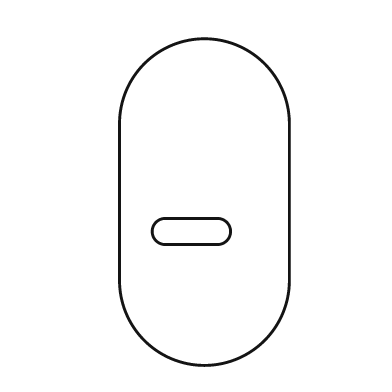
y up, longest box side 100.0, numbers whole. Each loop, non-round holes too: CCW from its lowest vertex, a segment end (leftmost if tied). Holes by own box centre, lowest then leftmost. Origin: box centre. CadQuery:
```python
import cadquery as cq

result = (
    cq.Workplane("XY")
    .moveTo(-26.0, -24.0)
    .threePointArc((0.0, -50.0), (26.0, -24.0))
    .lineTo(26.0, 24.0)
    .threePointArc((0.0, 50.0), (-26.0, 24.0))
    .close()
    .moveTo(-12.0, -13.0)
    .lineTo(4.0, -13.0)
    .threePointArc((8.0, -9.0), (4.0, -5.0))
    .lineTo(-12.0, -5.0)
    .threePointArc((-16.0, -9.0), (-12.0, -13.0))
    .close()
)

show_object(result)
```